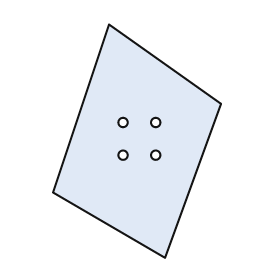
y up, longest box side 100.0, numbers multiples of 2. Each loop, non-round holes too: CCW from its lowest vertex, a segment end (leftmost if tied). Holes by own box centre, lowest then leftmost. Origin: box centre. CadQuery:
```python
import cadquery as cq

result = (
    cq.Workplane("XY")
    .moveTo(12.0, -50.0)
    .lineTo(36.0, 16.0)
    .lineTo(-12.0, 50.0)
    .lineTo(-36.0, -22.0)
    .close()
    .moveTo(-6.0, -6.0)
    .circle(2.0)
    .moveTo(8.0, -6.0)
    .circle(2.0)
    .moveTo(-6.0, 8.0)
    .circle(2.0)
    .moveTo(8.0, 8.0)
    .circle(2.0)
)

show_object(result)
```